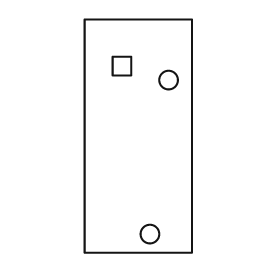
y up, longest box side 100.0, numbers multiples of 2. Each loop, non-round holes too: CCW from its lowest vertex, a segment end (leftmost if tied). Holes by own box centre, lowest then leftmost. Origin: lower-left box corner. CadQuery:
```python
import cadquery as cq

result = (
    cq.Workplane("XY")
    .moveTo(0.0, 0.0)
    .lineTo(46.0, 0.0)
    .lineTo(46.0, 100.0)
    .lineTo(0.0, 100.0)
    .close()
    .moveTo(28.0, 8.0)
    .circle(4.0)
    .moveTo(36.0, 74.0)
    .circle(4.0)
    .moveTo(12.0, 76.0)
    .lineTo(20.0, 76.0)
    .lineTo(20.0, 84.0)
    .lineTo(12.0, 84.0)
    .close()
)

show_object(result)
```